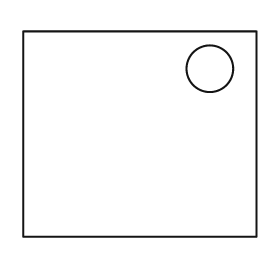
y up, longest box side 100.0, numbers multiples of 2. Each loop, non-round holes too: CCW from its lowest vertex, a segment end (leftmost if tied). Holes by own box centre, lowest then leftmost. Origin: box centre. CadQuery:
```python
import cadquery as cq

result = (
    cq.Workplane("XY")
    .moveTo(-50.0, -44.0)
    .lineTo(50.0, -44.0)
    .lineTo(50.0, 44.0)
    .lineTo(-50.0, 44.0)
    .close()
    .moveTo(30.0, 28.0)
    .circle(10.0)
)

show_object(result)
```